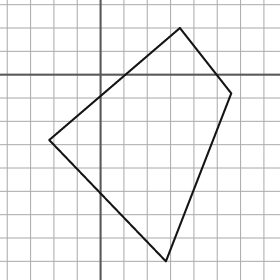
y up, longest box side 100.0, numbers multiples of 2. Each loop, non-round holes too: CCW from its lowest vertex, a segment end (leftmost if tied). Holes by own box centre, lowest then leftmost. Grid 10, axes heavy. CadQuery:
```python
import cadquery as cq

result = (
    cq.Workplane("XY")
    .moveTo(28.0, -80.0)
    .lineTo(56.0, -8.0)
    .lineTo(34.0, 20.0)
    .lineTo(-22.0, -28.0)
    .close()
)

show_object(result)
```